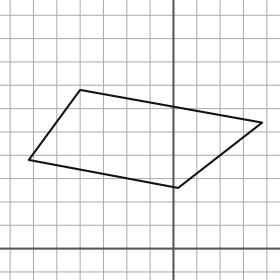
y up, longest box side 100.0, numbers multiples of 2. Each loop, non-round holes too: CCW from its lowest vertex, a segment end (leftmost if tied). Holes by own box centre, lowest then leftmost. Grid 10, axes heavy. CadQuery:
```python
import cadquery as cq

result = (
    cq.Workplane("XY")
    .moveTo(2.0, 26.0)
    .lineTo(38.0, 54.0)
    .lineTo(-40.0, 68.0)
    .lineTo(-62.0, 38.0)
    .close()
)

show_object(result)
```